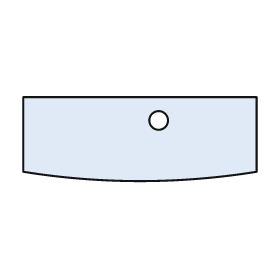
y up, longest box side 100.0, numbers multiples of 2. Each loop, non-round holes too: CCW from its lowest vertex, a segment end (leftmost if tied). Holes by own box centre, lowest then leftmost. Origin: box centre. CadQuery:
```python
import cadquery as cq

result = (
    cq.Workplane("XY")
    .moveTo(-50.0, -14.0)
    .threePointArc((0.0, -18.0), (50.0, -14.0))
    .lineTo(50.0, 18.0)
    .lineTo(-50.0, 18.0)
    .close()
    .moveTo(8.0, 8.0)
    .circle(4.0)
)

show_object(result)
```